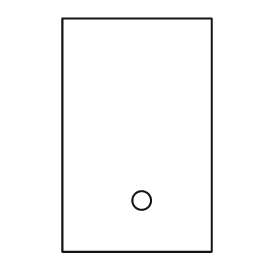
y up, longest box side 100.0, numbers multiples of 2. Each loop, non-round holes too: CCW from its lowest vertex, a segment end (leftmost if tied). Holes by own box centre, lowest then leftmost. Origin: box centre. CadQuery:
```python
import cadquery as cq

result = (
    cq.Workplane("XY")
    .moveTo(-32.0, -50.0)
    .lineTo(32.0, -50.0)
    .lineTo(32.0, 50.0)
    .lineTo(-32.0, 50.0)
    .close()
    .moveTo(2.0, -28.0)
    .circle(4.0)
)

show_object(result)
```